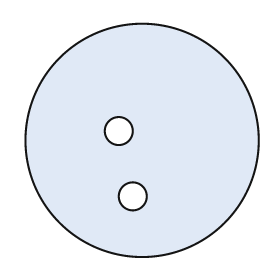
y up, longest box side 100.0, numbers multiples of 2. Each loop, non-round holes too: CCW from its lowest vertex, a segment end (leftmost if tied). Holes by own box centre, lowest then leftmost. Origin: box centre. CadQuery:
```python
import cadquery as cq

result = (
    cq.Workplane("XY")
    .moveTo(0.0, 0.0)
    .circle(50.0)
    .moveTo(-4.0, -24.0)
    .circle(6.0)
    .moveTo(-10.0, 4.0)
    .circle(6.0)
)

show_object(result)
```